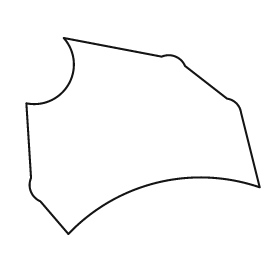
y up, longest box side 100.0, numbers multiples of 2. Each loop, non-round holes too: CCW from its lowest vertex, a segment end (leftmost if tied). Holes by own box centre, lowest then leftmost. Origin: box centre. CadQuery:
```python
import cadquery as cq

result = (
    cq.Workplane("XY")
    .moveTo(-32.0, -42.0)
    .threePointArc((6.0, -20.0), (50.0, -22.0))
    .lineTo(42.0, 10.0)
    .threePointArc((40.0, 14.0), (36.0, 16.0))
    .lineTo(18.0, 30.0)
    .threePointArc((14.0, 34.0), (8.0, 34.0))
    .lineTo(-34.0, 42.0)
    .threePointArc((-32.0, 22.0), (-50.0, 14.0))
    .lineTo(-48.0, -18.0)
    .threePointArc((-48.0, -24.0), (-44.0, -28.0))
    .close()
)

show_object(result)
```